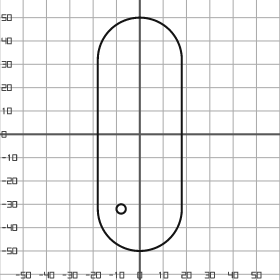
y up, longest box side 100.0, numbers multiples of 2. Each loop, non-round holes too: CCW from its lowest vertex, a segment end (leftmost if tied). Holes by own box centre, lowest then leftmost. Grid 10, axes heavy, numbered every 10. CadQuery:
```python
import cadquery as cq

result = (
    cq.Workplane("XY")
    .moveTo(-18.0, -32.0)
    .threePointArc((0.0, -50.0), (18.0, -32.0))
    .lineTo(18.0, 32.0)
    .threePointArc((0.0, 50.0), (-18.0, 32.0))
    .close()
    .moveTo(-8.0, -32.0)
    .circle(2.0)
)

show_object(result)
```